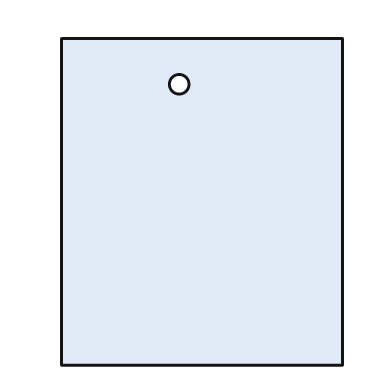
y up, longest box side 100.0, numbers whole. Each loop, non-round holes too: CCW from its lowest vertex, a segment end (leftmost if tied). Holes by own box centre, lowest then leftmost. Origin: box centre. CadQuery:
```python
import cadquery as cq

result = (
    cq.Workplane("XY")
    .moveTo(-43.0, -50.0)
    .lineTo(43.0, -50.0)
    .lineTo(43.0, 50.0)
    .lineTo(-43.0, 50.0)
    .close()
    .moveTo(-7.0, 36.0)
    .circle(3.0)
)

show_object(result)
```